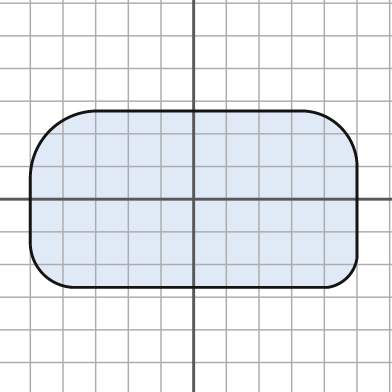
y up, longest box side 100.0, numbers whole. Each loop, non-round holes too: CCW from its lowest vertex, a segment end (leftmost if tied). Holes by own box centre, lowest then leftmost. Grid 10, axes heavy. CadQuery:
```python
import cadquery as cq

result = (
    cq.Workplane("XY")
    .moveTo(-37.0, -27.0)
    .lineTo(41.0, -27.0)
    .threePointArc((47.0, -24.0), (50.0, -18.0))
    .lineTo(50.0, 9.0)
    .threePointArc((45.0, 22.0), (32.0, 27.0))
    .lineTo(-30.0, 27.0)
    .threePointArc((-44.0, 21.0), (-50.0, 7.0))
    .lineTo(-50.0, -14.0)
    .threePointArc((-46.0, -23.0), (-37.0, -27.0))
    .close()
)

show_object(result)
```